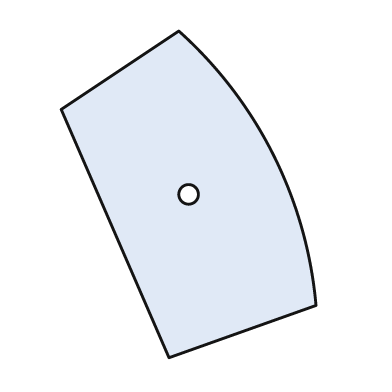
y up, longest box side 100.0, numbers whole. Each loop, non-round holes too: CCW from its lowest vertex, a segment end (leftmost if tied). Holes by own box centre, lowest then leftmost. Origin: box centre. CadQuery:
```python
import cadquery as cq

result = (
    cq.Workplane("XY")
    .moveTo(-6.0, -50.0)
    .lineTo(39.0, -34.0)
    .threePointArc((26.0, 12.0), (-3.0, 50.0))
    .lineTo(-39.0, 26.0)
    .close()
    .moveTo(0.0, 0.0)
    .circle(3.0)
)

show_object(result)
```